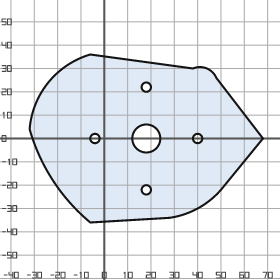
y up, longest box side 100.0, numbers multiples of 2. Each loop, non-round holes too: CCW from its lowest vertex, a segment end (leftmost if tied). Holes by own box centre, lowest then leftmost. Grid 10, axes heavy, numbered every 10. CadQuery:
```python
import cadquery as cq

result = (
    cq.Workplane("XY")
    .moveTo(-6.0, -36.0)
    .lineTo(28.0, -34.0)
    .threePointArc((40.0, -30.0), (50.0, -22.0))
    .lineTo(68.0, 0.0)
    .lineTo(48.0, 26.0)
    .threePointArc((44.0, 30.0), (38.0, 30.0))
    .lineTo(-6.0, 36.0)
    .threePointArc((-24.0, 24.0), (-32.0, 4.0))
    .threePointArc((-22.0, -18.0), (-6.0, -36.0))
    .close()
    .moveTo(18.0, -22.0)
    .circle(2.0)
    .moveTo(-4.0, 0.0)
    .circle(2.0)
    .moveTo(18.0, 0.0)
    .circle(6.0)
    .moveTo(40.0, 0.0)
    .circle(2.0)
    .moveTo(18.0, 22.0)
    .circle(2.0)
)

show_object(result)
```